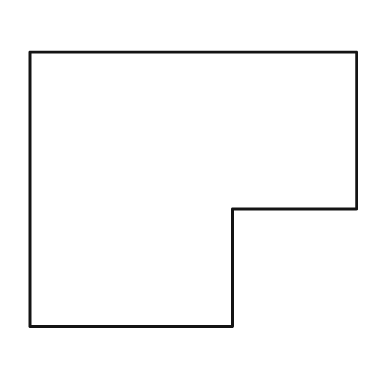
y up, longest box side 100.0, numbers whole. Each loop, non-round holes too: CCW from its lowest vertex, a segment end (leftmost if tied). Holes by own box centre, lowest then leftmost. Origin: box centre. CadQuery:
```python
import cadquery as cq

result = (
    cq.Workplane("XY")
    .moveTo(-50.0, -42.0)
    .lineTo(12.0, -42.0)
    .lineTo(12.0, -6.0)
    .lineTo(50.0, -6.0)
    .lineTo(50.0, 42.0)
    .lineTo(-50.0, 42.0)
    .close()
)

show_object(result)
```